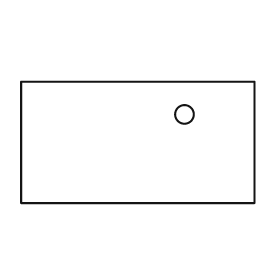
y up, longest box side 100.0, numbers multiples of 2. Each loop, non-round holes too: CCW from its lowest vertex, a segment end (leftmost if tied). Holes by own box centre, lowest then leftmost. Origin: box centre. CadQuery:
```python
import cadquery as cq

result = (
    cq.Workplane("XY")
    .moveTo(-50.0, -26.0)
    .lineTo(50.0, -26.0)
    .lineTo(50.0, 26.0)
    .lineTo(-50.0, 26.0)
    .close()
    .moveTo(20.0, 12.0)
    .circle(4.0)
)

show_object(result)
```